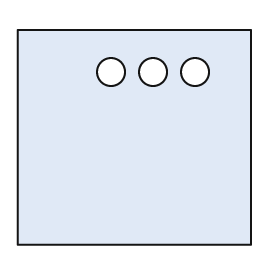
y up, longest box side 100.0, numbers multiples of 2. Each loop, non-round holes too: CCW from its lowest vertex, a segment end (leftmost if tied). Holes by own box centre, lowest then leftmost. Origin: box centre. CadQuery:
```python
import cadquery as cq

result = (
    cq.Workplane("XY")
    .moveTo(-50.0, -46.0)
    .lineTo(50.0, -46.0)
    .lineTo(50.0, 46.0)
    .lineTo(-50.0, 46.0)
    .close()
    .moveTo(-10.0, 28.0)
    .circle(6.0)
    .moveTo(8.0, 28.0)
    .circle(6.0)
    .moveTo(26.0, 28.0)
    .circle(6.0)
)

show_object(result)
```